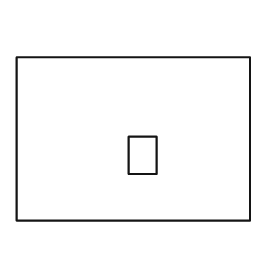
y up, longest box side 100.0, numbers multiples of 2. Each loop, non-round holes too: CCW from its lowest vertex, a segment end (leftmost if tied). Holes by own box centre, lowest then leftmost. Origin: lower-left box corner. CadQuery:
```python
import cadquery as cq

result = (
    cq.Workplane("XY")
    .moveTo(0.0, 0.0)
    .lineTo(100.0, 0.0)
    .lineTo(100.0, 70.0)
    .lineTo(0.0, 70.0)
    .close()
    .moveTo(48.0, 20.0)
    .lineTo(60.0, 20.0)
    .lineTo(60.0, 36.0)
    .lineTo(48.0, 36.0)
    .close()
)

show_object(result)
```